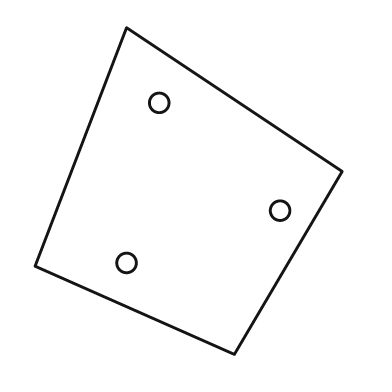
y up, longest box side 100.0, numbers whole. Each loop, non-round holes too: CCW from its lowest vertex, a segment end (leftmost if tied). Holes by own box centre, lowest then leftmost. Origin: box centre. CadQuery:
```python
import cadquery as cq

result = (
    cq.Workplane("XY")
    .moveTo(14.0, -50.0)
    .lineTo(47.0, 6.0)
    .lineTo(-19.0, 50.0)
    .lineTo(-47.0, -23.0)
    .close()
    .moveTo(-19.0, -22.0)
    .circle(3.0)
    .moveTo(28.0, -6.0)
    .circle(3.0)
    .moveTo(-9.0, 27.0)
    .circle(3.0)
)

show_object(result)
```